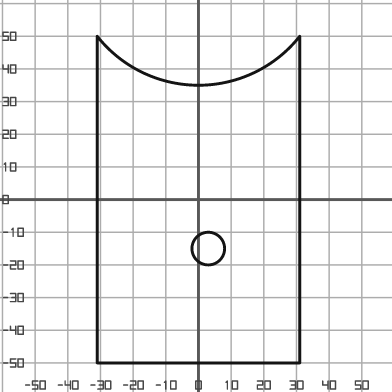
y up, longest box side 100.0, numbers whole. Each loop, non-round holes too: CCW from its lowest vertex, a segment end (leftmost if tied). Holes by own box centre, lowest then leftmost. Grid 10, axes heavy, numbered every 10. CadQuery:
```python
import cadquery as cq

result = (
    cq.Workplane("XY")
    .moveTo(-31.0, -50.0)
    .lineTo(31.0, -50.0)
    .lineTo(31.0, 50.0)
    .threePointArc((0.0, 35.0), (-31.0, 50.0))
    .close()
    .moveTo(3.0, -15.0)
    .circle(5.0)
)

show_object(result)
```